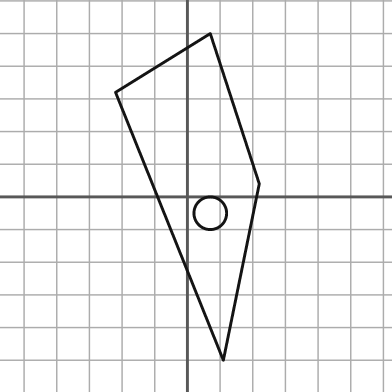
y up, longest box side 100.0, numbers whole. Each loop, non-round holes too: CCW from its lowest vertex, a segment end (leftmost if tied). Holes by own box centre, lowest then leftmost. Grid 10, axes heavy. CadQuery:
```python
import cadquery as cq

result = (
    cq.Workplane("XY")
    .moveTo(11.0, -50.0)
    .lineTo(22.0, 4.0)
    .lineTo(7.0, 50.0)
    .lineTo(-22.0, 32.0)
    .close()
    .moveTo(7.0, -5.0)
    .circle(5.0)
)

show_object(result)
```